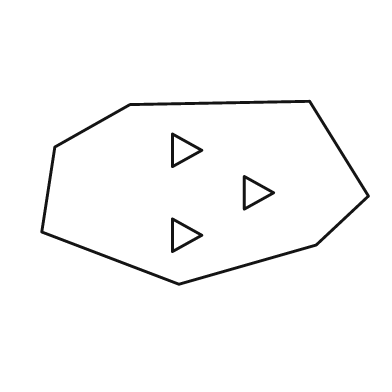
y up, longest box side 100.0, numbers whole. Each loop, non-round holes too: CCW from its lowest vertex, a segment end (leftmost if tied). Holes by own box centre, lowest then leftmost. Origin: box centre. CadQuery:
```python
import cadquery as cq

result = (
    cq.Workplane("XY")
    .moveTo(-8.0, -28.0)
    .lineTo(34.0, -16.0)
    .lineTo(50.0, -1.0)
    .lineTo(32.0, 28.0)
    .lineTo(-23.0, 27.0)
    .lineTo(-46.0, 14.0)
    .lineTo(-50.0, -12.0)
    .close()
    .moveTo(-10.0, -18.0)
    .lineTo(-1.0, -13.0)
    .lineTo(-10.0, -8.0)
    .close()
    .moveTo(12.0, -5.0)
    .lineTo(21.0, 0.0)
    .lineTo(12.0, 5.0)
    .close()
    .moveTo(-10.0, 8.0)
    .lineTo(-1.0, 13.0)
    .lineTo(-10.0, 18.0)
    .close()
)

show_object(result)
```